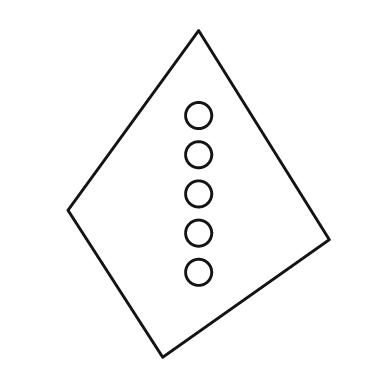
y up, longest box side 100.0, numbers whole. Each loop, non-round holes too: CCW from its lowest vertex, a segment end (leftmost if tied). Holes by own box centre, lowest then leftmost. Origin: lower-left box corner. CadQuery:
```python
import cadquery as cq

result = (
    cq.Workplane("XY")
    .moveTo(29.0, 0.0)
    .lineTo(80.0, 36.0)
    .lineTo(40.0, 100.0)
    .lineTo(0.0, 45.0)
    .close()
    .moveTo(40.0, 26.0)
    .circle(4.0)
    .moveTo(40.0, 38.0)
    .circle(4.0)
    .moveTo(40.0, 50.0)
    .circle(4.0)
    .moveTo(40.0, 62.0)
    .circle(4.0)
    .moveTo(40.0, 74.0)
    .circle(4.0)
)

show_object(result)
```